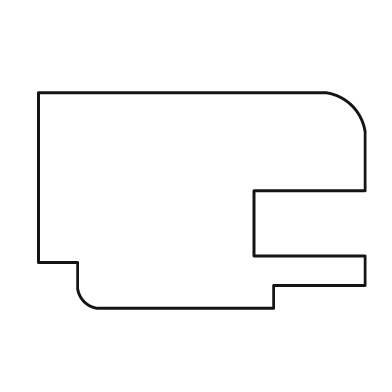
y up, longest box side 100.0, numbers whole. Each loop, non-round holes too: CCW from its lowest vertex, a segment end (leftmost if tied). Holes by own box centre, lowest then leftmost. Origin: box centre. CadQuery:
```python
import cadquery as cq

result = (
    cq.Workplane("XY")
    .moveTo(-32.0, -33.0)
    .lineTo(22.0, -33.0)
    .lineTo(22.0, -26.0)
    .lineTo(50.0, -26.0)
    .lineTo(50.0, -17.0)
    .lineTo(16.0, -17.0)
    .lineTo(16.0, 3.0)
    .lineTo(50.0, 3.0)
    .lineTo(50.0, 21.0)
    .threePointArc((46.0, 29.0), (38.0, 33.0))
    .lineTo(-50.0, 33.0)
    .lineTo(-50.0, -19.0)
    .lineTo(-38.0, -19.0)
    .lineTo(-38.0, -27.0)
    .threePointArc((-36.0, -31.0), (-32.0, -33.0))
    .close()
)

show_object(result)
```